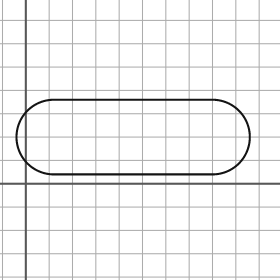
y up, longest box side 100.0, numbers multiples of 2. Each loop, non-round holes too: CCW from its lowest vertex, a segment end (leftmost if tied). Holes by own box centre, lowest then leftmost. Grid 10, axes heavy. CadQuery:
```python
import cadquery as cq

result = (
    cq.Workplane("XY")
    .moveTo(12.0, 4.0)
    .lineTo(80.0, 4.0)
    .threePointArc((96.0, 20.0), (80.0, 36.0))
    .lineTo(12.0, 36.0)
    .threePointArc((-4.0, 20.0), (12.0, 4.0))
    .close()
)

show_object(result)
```